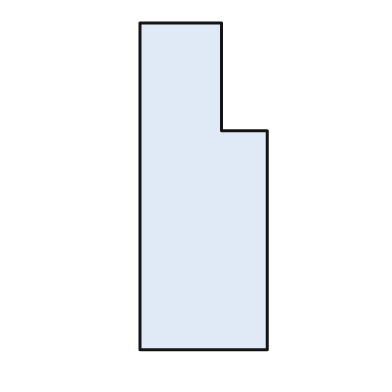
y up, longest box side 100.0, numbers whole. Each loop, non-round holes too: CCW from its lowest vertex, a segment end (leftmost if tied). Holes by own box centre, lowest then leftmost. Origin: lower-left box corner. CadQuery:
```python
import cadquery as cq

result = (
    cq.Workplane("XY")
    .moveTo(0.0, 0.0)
    .lineTo(39.0, 0.0)
    .lineTo(39.0, 67.0)
    .lineTo(25.0, 67.0)
    .lineTo(25.0, 100.0)
    .lineTo(0.0, 100.0)
    .close()
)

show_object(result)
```